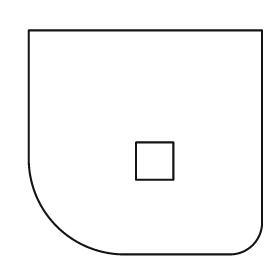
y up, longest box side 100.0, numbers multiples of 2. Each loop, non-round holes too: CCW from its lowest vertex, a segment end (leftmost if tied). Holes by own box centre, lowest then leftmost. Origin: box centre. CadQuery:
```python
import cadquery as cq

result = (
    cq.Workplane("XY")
    .moveTo(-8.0, -48.0)
    .lineTo(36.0, -48.0)
    .threePointArc((46.0, -44.0), (50.0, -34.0))
    .lineTo(50.0, 48.0)
    .lineTo(-50.0, 48.0)
    .lineTo(-50.0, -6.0)
    .threePointArc((-38.0, -36.0), (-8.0, -48.0))
    .close()
    .moveTo(-4.0, -16.0)
    .lineTo(12.0, -16.0)
    .lineTo(12.0, 0.0)
    .lineTo(-4.0, 0.0)
    .close()
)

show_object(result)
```